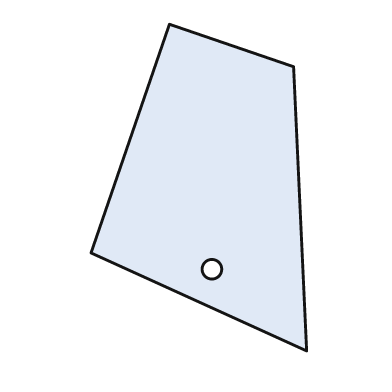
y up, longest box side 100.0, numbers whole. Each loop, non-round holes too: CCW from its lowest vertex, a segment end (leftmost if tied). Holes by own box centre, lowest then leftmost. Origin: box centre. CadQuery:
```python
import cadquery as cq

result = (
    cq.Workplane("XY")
    .moveTo(33.0, -50.0)
    .lineTo(29.0, 37.0)
    .lineTo(-9.0, 50.0)
    .lineTo(-33.0, -20.0)
    .close()
    .moveTo(4.0, -25.0)
    .circle(3.0)
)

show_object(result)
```